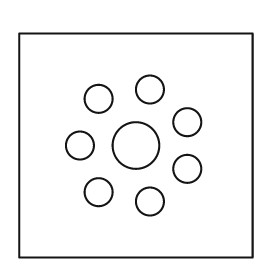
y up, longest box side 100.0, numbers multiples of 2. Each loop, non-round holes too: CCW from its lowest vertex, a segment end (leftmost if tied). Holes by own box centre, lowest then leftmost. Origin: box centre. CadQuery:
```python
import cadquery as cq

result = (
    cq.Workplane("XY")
    .moveTo(-50.0, -48.0)
    .lineTo(50.0, -48.0)
    .lineTo(50.0, 48.0)
    .lineTo(-50.0, 48.0)
    .close()
    .moveTo(6.0, -24.0)
    .circle(6.0)
    .moveTo(-16.0, -20.0)
    .circle(6.0)
    .moveTo(22.0, -10.0)
    .circle(6.0)
    .moveTo(-24.0, 0.0)
    .circle(6.0)
    .moveTo(0.0, 0.0)
    .circle(10.0)
    .moveTo(22.0, 10.0)
    .circle(6.0)
    .moveTo(-16.0, 20.0)
    .circle(6.0)
    .moveTo(6.0, 24.0)
    .circle(6.0)
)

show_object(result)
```